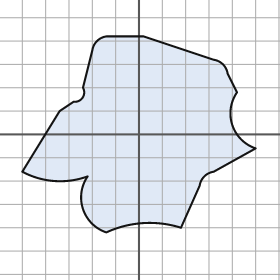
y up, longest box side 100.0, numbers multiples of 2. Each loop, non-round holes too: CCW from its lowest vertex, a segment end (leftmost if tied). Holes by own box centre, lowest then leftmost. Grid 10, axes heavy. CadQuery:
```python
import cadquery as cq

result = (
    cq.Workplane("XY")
    .moveTo(-14.0, -42.0)
    .threePointArc((2.0, -38.0), (18.0, -40.0))
    .lineTo(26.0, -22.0)
    .threePointArc((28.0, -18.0), (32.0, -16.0))
    .lineTo(50.0, -6.0)
    .threePointArc((40.0, 4.0), (42.0, 18.0))
    .lineTo(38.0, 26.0)
    .threePointArc((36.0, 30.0), (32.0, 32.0))
    .lineTo(2.0, 42.0)
    .lineTo(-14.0, 42.0)
    .threePointArc((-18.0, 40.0), (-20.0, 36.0))
    .lineTo(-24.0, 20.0)
    .threePointArc((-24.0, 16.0), (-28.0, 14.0))
    .lineTo(-34.0, 10.0)
    .lineTo(-50.0, -16.0)
    .threePointArc((-36.0, -20.0), (-22.0, -18.0))
    .threePointArc((-24.0, -32.0), (-14.0, -42.0))
    .close()
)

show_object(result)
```